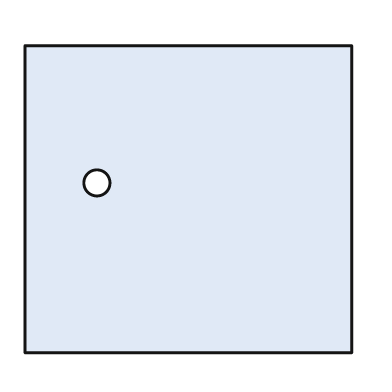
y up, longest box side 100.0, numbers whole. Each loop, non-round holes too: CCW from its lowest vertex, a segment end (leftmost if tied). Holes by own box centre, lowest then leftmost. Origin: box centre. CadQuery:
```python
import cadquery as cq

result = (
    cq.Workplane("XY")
    .moveTo(-50.0, -47.0)
    .lineTo(50.0, -47.0)
    .lineTo(50.0, 47.0)
    .lineTo(-50.0, 47.0)
    .close()
    .moveTo(-28.0, 5.0)
    .circle(4.0)
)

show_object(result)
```